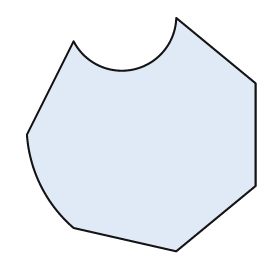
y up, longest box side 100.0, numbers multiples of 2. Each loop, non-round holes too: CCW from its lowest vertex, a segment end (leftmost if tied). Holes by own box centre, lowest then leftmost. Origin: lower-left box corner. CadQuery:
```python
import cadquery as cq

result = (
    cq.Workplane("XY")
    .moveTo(64.0, 0.0)
    .lineTo(98.0, 28.0)
    .lineTo(98.0, 72.0)
    .lineTo(64.0, 100.0)
    .threePointArc((46.0, 78.0), (20.0, 90.0))
    .lineTo(0.0, 50.0)
    .threePointArc((6.0, 28.0), (20.0, 10.0))
    .close()
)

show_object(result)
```